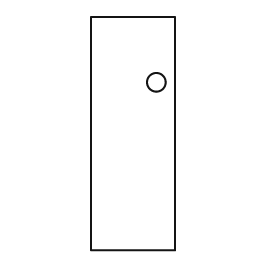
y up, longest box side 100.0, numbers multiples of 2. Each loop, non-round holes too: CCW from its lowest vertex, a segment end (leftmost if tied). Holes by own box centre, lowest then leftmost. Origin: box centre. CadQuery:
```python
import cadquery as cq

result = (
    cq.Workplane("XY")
    .moveTo(-18.0, -50.0)
    .lineTo(18.0, -50.0)
    .lineTo(18.0, 50.0)
    .lineTo(-18.0, 50.0)
    .close()
    .moveTo(10.0, 22.0)
    .circle(4.0)
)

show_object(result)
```